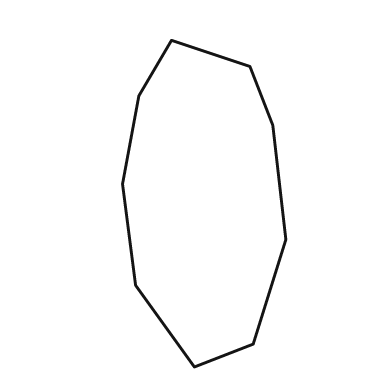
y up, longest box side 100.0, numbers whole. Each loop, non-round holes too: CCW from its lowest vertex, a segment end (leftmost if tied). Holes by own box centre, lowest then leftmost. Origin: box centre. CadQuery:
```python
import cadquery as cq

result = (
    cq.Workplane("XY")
    .moveTo(-3.0, -50.0)
    .lineTo(15.0, -43.0)
    .lineTo(25.0, -11.0)
    .lineTo(21.0, 24.0)
    .lineTo(14.0, 42.0)
    .lineTo(-10.0, 50.0)
    .lineTo(-20.0, 33.0)
    .lineTo(-25.0, 6.0)
    .lineTo(-21.0, -25.0)
    .close()
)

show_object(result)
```